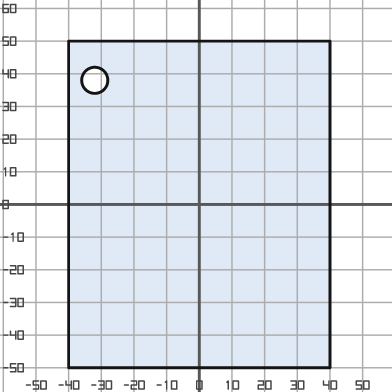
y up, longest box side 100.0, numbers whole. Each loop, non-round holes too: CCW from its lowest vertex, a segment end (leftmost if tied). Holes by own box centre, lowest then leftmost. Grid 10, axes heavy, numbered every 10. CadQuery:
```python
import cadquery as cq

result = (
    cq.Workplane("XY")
    .moveTo(-40.0, -50.0)
    .lineTo(40.0, -50.0)
    .lineTo(40.0, 50.0)
    .lineTo(-40.0, 50.0)
    .close()
    .moveTo(-32.0, 38.0)
    .circle(4.0)
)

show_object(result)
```